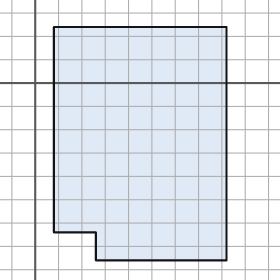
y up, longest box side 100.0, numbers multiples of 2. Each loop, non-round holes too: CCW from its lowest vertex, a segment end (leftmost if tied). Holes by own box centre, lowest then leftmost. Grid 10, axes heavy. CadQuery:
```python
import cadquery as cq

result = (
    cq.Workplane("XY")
    .moveTo(26.0, -76.0)
    .lineTo(82.0, -76.0)
    .lineTo(82.0, 24.0)
    .lineTo(8.0, 24.0)
    .lineTo(8.0, -64.0)
    .lineTo(26.0, -64.0)
    .close()
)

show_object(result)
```